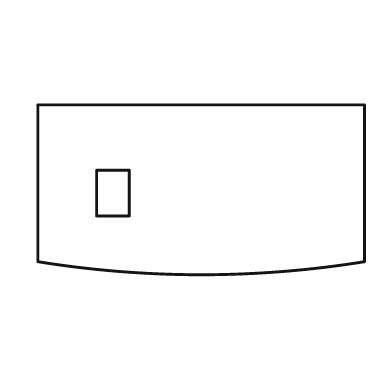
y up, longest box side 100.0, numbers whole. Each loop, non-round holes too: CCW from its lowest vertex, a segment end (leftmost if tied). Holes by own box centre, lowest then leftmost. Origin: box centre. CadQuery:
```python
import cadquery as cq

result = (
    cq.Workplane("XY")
    .moveTo(-50.0, -22.0)
    .threePointArc((0.0, -26.0), (50.0, -22.0))
    .lineTo(50.0, 26.0)
    .lineTo(-50.0, 26.0)
    .close()
    .moveTo(-32.0, -8.0)
    .lineTo(-22.0, -8.0)
    .lineTo(-22.0, 6.0)
    .lineTo(-32.0, 6.0)
    .close()
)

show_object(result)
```